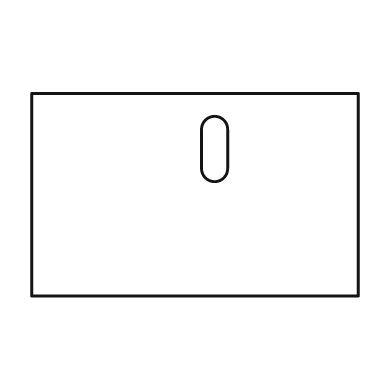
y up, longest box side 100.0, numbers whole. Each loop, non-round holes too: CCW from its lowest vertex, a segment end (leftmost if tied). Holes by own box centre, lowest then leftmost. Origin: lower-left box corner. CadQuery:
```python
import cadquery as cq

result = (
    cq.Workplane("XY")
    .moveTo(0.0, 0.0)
    .lineTo(100.0, 0.0)
    .lineTo(100.0, 62.0)
    .lineTo(0.0, 62.0)
    .close()
    .moveTo(52.0, 39.0)
    .threePointArc((56.0, 35.0), (60.0, 39.0))
    .lineTo(60.0, 51.0)
    .threePointArc((56.0, 55.0), (52.0, 51.0))
    .close()
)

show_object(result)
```